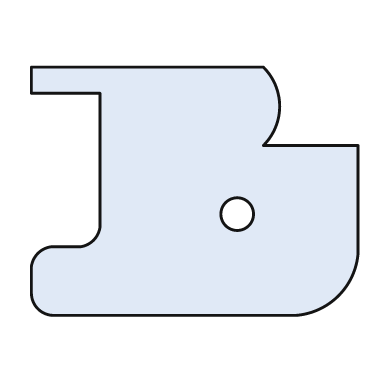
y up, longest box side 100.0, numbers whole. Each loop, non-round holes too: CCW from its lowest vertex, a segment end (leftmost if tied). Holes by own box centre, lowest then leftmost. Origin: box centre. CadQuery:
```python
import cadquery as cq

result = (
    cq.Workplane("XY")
    .moveTo(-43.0, -38.0)
    .lineTo(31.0, -38.0)
    .threePointArc((44.0, -32.0), (50.0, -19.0))
    .lineTo(50.0, 14.0)
    .lineTo(21.0, 14.0)
    .threePointArc((26.0, 26.0), (21.0, 38.0))
    .lineTo(-50.0, 38.0)
    .lineTo(-50.0, 30.0)
    .lineTo(-29.0, 30.0)
    .lineTo(-29.0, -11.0)
    .threePointArc((-31.0, -15.0), (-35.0, -17.0))
    .lineTo(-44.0, -17.0)
    .threePointArc((-48.0, -19.0), (-50.0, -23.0))
    .lineTo(-50.0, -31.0)
    .threePointArc((-48.0, -36.0), (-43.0, -38.0))
    .close()
    .moveTo(13.0, -7.0)
    .circle(5.0)
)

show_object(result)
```